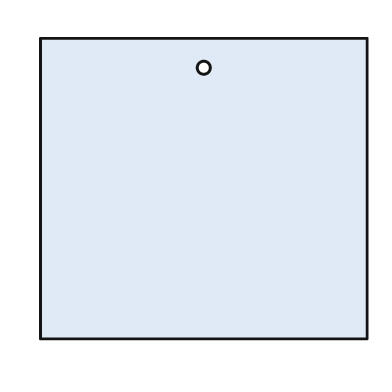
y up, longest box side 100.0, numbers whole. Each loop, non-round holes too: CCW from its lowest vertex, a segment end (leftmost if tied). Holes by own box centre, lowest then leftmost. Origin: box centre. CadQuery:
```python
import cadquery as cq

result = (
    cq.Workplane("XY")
    .moveTo(-50.0, -46.0)
    .lineTo(50.0, -46.0)
    .lineTo(50.0, 46.0)
    .lineTo(-50.0, 46.0)
    .close()
    .moveTo(0.0, 37.0)
    .circle(2.0)
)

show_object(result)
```